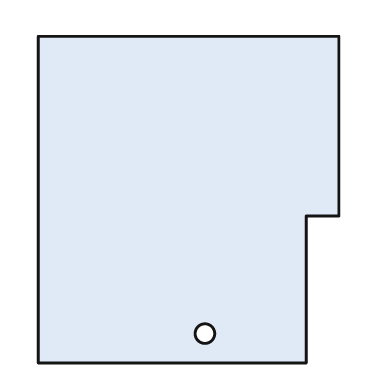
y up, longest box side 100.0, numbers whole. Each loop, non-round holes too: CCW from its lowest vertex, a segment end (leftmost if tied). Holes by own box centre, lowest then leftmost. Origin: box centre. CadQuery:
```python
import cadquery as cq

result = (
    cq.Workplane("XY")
    .moveTo(-46.0, -50.0)
    .lineTo(36.0, -50.0)
    .lineTo(36.0, -5.0)
    .lineTo(46.0, -5.0)
    .lineTo(46.0, 50.0)
    .lineTo(-46.0, 50.0)
    .close()
    .moveTo(5.0, -41.0)
    .circle(3.0)
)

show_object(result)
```